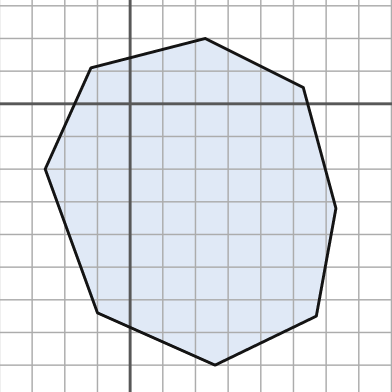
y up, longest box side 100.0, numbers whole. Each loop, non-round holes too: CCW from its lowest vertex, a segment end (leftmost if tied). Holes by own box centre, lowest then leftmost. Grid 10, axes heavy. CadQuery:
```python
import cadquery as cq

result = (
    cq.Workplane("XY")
    .moveTo(26.0, -80.0)
    .lineTo(57.0, -65.0)
    .lineTo(63.0, -32.0)
    .lineTo(53.0, 5.0)
    .lineTo(23.0, 20.0)
    .lineTo(-12.0, 11.0)
    .lineTo(-26.0, -20.0)
    .lineTo(-10.0, -64.0)
    .close()
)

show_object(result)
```